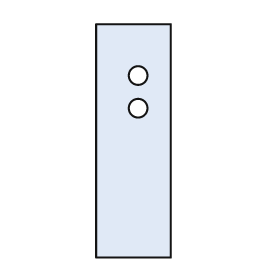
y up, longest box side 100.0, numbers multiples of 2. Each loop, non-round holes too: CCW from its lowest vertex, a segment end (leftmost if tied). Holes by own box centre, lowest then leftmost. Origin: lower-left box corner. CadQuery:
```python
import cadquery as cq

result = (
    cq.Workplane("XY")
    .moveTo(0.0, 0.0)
    .lineTo(32.0, 0.0)
    .lineTo(32.0, 100.0)
    .lineTo(0.0, 100.0)
    .close()
    .moveTo(18.0, 64.0)
    .circle(4.0)
    .moveTo(18.0, 78.0)
    .circle(4.0)
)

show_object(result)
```